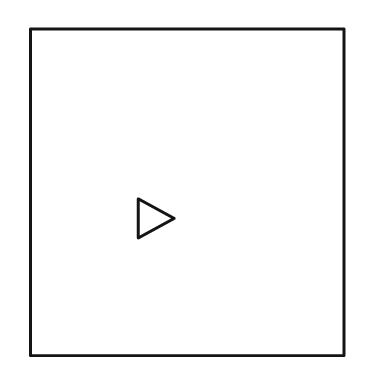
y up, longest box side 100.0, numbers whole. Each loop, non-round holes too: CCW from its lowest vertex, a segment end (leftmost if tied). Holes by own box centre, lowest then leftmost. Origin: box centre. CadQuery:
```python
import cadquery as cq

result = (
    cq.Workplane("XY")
    .moveTo(-48.0, -50.0)
    .lineTo(48.0, -50.0)
    .lineTo(48.0, 50.0)
    .lineTo(-48.0, 50.0)
    .close()
    .moveTo(-15.0, -14.0)
    .lineTo(-4.0, -8.0)
    .lineTo(-15.0, -2.0)
    .close()
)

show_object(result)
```